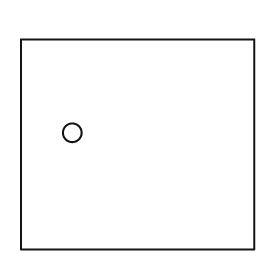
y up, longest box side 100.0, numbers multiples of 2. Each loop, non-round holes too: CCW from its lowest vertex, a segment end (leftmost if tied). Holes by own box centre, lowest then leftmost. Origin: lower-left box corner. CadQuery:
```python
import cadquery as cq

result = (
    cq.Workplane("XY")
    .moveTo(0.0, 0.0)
    .lineTo(100.0, 0.0)
    .lineTo(100.0, 90.0)
    .lineTo(0.0, 90.0)
    .close()
    .moveTo(22.0, 50.0)
    .circle(4.0)
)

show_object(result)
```